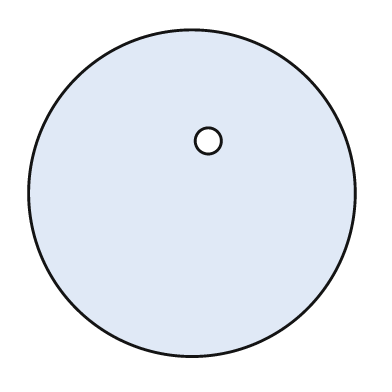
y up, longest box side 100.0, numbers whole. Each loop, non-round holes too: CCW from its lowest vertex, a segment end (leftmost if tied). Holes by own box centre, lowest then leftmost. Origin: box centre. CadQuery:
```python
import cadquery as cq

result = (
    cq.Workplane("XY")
    .moveTo(0.0, 0.0)
    .circle(50.0)
    .moveTo(5.0, 16.0)
    .circle(4.0)
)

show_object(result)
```